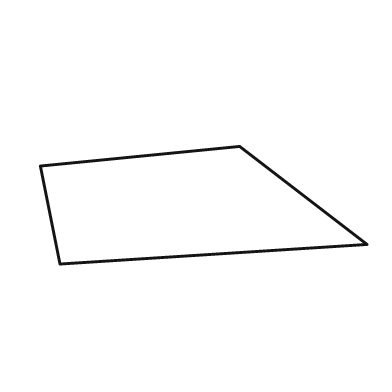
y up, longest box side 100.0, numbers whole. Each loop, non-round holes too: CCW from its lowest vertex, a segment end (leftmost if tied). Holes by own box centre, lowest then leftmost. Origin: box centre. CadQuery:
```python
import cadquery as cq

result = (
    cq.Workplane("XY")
    .moveTo(-44.0, -18.0)
    .lineTo(50.0, -12.0)
    .lineTo(11.0, 18.0)
    .lineTo(-50.0, 12.0)
    .close()
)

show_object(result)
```